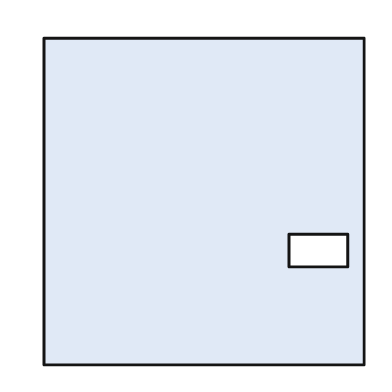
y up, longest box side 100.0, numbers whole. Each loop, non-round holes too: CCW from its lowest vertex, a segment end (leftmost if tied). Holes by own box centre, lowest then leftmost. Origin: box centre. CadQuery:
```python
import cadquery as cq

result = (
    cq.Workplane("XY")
    .moveTo(-49.0, -50.0)
    .lineTo(49.0, -50.0)
    .lineTo(49.0, 50.0)
    .lineTo(-49.0, 50.0)
    .close()
    .moveTo(26.0, -20.0)
    .lineTo(44.0, -20.0)
    .lineTo(44.0, -10.0)
    .lineTo(26.0, -10.0)
    .close()
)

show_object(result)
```